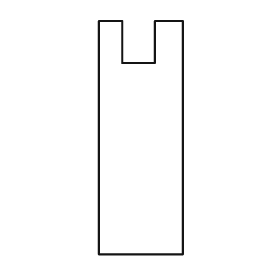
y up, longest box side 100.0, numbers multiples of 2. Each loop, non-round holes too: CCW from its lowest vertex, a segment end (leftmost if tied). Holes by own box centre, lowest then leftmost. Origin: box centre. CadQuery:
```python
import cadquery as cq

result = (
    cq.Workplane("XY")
    .moveTo(-18.0, -50.0)
    .lineTo(18.0, -50.0)
    .lineTo(18.0, 50.0)
    .lineTo(6.0, 50.0)
    .lineTo(6.0, 32.0)
    .lineTo(-8.0, 32.0)
    .lineTo(-8.0, 50.0)
    .lineTo(-18.0, 50.0)
    .close()
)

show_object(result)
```